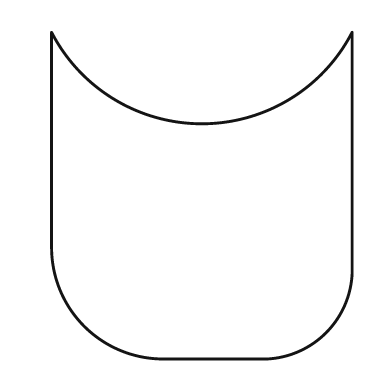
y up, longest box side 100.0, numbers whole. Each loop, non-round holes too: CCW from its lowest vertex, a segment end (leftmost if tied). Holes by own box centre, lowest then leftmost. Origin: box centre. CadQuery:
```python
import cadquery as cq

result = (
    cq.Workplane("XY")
    .moveTo(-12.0, -50.0)
    .lineTo(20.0, -50.0)
    .threePointArc((38.0, -42.0), (46.0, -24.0))
    .lineTo(46.0, 50.0)
    .threePointArc((0.0, 22.0), (-46.0, 50.0))
    .lineTo(-46.0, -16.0)
    .threePointArc((-36.0, -40.0), (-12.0, -50.0))
    .close()
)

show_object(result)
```